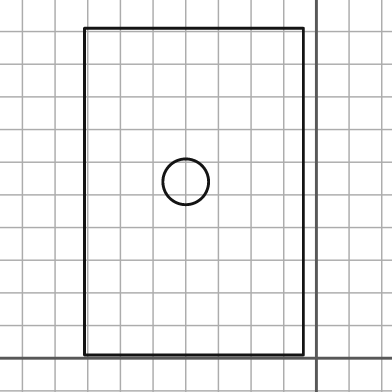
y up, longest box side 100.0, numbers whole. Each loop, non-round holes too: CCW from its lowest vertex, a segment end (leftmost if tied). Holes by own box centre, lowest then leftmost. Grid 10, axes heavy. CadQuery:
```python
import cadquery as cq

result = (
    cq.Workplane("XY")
    .moveTo(-71.0, 1.0)
    .lineTo(-4.0, 1.0)
    .lineTo(-4.0, 101.0)
    .lineTo(-71.0, 101.0)
    .close()
    .moveTo(-40.0, 54.0)
    .circle(7.0)
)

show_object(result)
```